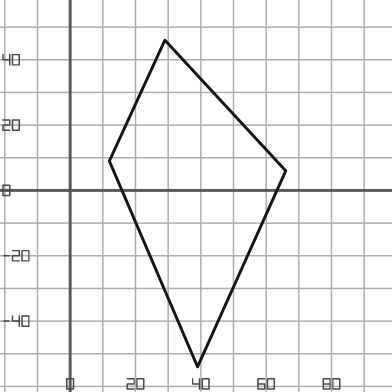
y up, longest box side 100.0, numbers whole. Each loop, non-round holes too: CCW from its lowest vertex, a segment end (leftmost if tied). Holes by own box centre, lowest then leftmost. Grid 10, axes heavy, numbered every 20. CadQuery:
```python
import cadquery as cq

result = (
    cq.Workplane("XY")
    .moveTo(39.0, -54.0)
    .lineTo(66.0, 6.0)
    .lineTo(29.0, 46.0)
    .lineTo(12.0, 9.0)
    .close()
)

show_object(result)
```